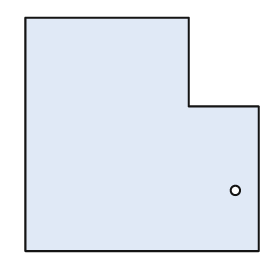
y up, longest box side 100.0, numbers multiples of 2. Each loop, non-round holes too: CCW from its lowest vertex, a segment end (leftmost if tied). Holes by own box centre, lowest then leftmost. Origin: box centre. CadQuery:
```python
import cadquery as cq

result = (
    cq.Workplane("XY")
    .moveTo(-50.0, -50.0)
    .lineTo(50.0, -50.0)
    .lineTo(50.0, 12.0)
    .lineTo(20.0, 12.0)
    .lineTo(20.0, 50.0)
    .lineTo(-50.0, 50.0)
    .close()
    .moveTo(40.0, -24.0)
    .circle(2.0)
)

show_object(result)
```